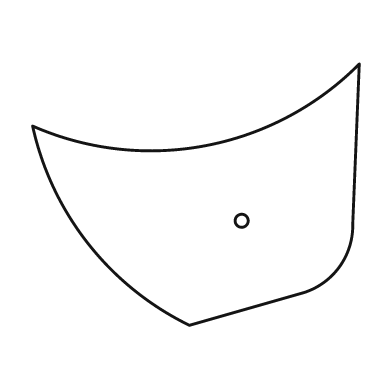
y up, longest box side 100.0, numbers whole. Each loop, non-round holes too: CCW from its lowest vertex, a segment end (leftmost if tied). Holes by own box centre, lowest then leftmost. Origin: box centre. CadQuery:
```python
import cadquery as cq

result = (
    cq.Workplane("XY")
    .moveTo(-2.0, -40.0)
    .lineTo(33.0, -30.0)
    .threePointArc((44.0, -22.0), (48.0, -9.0))
    .lineTo(50.0, 40.0)
    .threePointArc((3.0, 15.0), (-50.0, 21.0))
    .threePointArc((-33.0, -15.0), (-2.0, -40.0))
    .close()
    .moveTo(14.0, -8.0)
    .circle(2.0)
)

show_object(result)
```